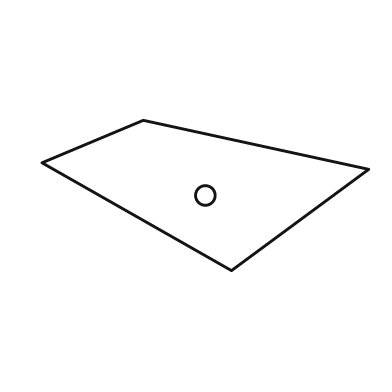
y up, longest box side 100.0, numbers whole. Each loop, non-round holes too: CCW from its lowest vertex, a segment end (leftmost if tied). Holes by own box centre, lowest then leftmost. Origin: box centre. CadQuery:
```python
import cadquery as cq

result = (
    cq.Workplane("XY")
    .moveTo(8.0, -23.0)
    .lineTo(50.0, 8.0)
    .lineTo(-19.0, 23.0)
    .lineTo(-50.0, 10.0)
    .close()
    .moveTo(0.0, 0.0)
    .circle(3.0)
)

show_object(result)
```